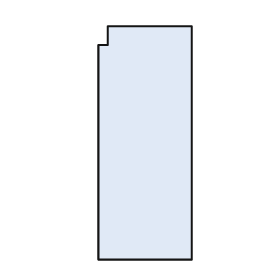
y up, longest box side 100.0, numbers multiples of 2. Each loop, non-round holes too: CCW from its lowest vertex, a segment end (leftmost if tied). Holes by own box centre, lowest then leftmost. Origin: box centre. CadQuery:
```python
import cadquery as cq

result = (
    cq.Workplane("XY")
    .moveTo(-20.0, -50.0)
    .lineTo(20.0, -50.0)
    .lineTo(20.0, 50.0)
    .lineTo(-16.0, 50.0)
    .lineTo(-16.0, 42.0)
    .lineTo(-20.0, 42.0)
    .close()
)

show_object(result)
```